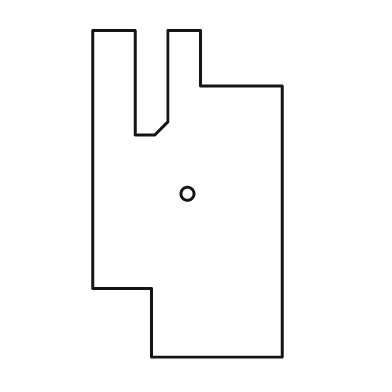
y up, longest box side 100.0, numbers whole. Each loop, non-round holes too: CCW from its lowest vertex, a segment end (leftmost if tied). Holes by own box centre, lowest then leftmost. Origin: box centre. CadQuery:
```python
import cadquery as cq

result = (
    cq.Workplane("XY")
    .moveTo(-11.0, -50.0)
    .lineTo(29.0, -50.0)
    .lineTo(29.0, 33.0)
    .lineTo(4.0, 33.0)
    .lineTo(4.0, 50.0)
    .lineTo(-6.0, 50.0)
    .lineTo(-6.0, 22.0)
    .lineTo(-10.0, 18.0)
    .lineTo(-16.0, 18.0)
    .lineTo(-16.0, 50.0)
    .lineTo(-29.0, 50.0)
    .lineTo(-29.0, -29.0)
    .lineTo(-11.0, -29.0)
    .close()
    .moveTo(0.0, 0.0)
    .circle(2.0)
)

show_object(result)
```